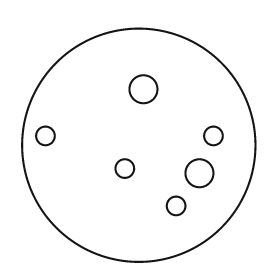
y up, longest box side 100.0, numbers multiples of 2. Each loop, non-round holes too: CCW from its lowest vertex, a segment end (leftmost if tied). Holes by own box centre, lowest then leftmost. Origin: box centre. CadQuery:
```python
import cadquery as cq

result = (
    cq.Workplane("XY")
    .moveTo(0.0, 0.0)
    .circle(50.0)
    .moveTo(16.0, -26.0)
    .circle(4.0)
    .moveTo(26.0, -12.0)
    .circle(6.0)
    .moveTo(-6.0, -10.0)
    .circle(4.0)
    .moveTo(-40.0, 4.0)
    .circle(4.0)
    .moveTo(32.0, 4.0)
    .circle(4.0)
    .moveTo(2.0, 24.0)
    .circle(6.0)
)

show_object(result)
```